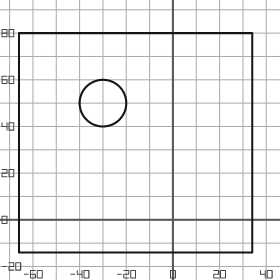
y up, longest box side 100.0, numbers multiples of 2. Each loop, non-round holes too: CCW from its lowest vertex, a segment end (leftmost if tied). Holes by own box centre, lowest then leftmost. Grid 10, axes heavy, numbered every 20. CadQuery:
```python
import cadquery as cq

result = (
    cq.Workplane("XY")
    .moveTo(-66.0, -14.0)
    .lineTo(34.0, -14.0)
    .lineTo(34.0, 80.0)
    .lineTo(-66.0, 80.0)
    .close()
    .moveTo(-30.0, 50.0)
    .circle(10.0)
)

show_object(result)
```